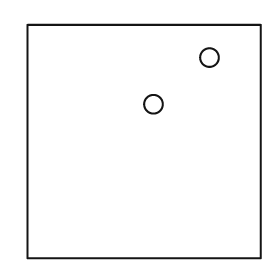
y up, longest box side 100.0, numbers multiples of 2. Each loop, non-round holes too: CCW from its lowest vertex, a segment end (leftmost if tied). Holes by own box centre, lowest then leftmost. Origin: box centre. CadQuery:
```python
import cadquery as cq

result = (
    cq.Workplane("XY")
    .moveTo(-50.0, -50.0)
    .lineTo(50.0, -50.0)
    .lineTo(50.0, 50.0)
    .lineTo(-50.0, 50.0)
    .close()
    .moveTo(4.0, 16.0)
    .circle(4.0)
    .moveTo(28.0, 36.0)
    .circle(4.0)
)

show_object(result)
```